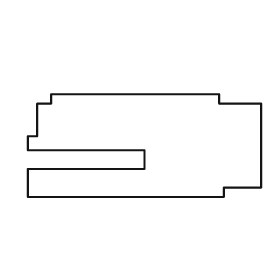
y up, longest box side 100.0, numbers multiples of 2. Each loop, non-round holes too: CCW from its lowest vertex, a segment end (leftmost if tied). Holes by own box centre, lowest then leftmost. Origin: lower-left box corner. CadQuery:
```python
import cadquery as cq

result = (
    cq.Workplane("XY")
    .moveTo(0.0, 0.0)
    .lineTo(84.0, 0.0)
    .lineTo(84.0, 4.0)
    .lineTo(100.0, 4.0)
    .lineTo(100.0, 40.0)
    .lineTo(82.0, 40.0)
    .lineTo(82.0, 44.0)
    .lineTo(10.0, 44.0)
    .lineTo(10.0, 40.0)
    .lineTo(4.0, 40.0)
    .lineTo(4.0, 26.0)
    .lineTo(0.0, 26.0)
    .lineTo(0.0, 20.0)
    .lineTo(50.0, 20.0)
    .lineTo(50.0, 12.0)
    .lineTo(0.0, 12.0)
    .close()
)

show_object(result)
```